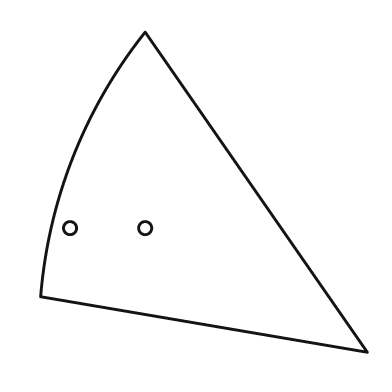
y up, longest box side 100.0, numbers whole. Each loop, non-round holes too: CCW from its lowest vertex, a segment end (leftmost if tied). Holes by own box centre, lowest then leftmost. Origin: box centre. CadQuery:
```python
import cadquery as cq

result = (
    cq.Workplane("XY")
    .moveTo(50.0, -49.0)
    .lineTo(-18.0, 49.0)
    .threePointArc((-40.0, 11.0), (-50.0, -32.0))
    .close()
    .moveTo(-41.0, -11.0)
    .circle(2.0)
    .moveTo(-18.0, -11.0)
    .circle(2.0)
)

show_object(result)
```